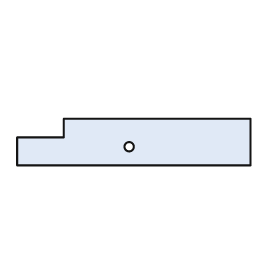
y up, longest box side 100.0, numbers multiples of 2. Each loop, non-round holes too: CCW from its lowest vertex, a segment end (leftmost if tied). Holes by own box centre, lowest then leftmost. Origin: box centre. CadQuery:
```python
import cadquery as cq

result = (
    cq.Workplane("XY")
    .moveTo(-50.0, -10.0)
    .lineTo(50.0, -10.0)
    .lineTo(50.0, 10.0)
    .lineTo(-30.0, 10.0)
    .lineTo(-30.0, 2.0)
    .lineTo(-50.0, 2.0)
    .close()
    .moveTo(-2.0, -2.0)
    .circle(2.0)
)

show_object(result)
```